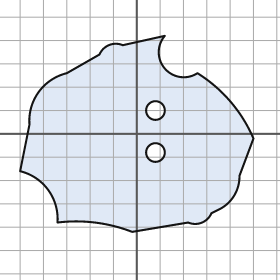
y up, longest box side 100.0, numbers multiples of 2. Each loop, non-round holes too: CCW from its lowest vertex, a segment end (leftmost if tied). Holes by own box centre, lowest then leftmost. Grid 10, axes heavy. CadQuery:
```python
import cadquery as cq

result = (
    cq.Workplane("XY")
    .moveTo(-2.0, -42.0)
    .lineTo(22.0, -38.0)
    .threePointArc((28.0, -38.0), (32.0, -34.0))
    .lineTo(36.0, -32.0)
    .threePointArc((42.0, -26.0), (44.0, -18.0))
    .lineTo(50.0, -2.0)
    .threePointArc((40.0, 14.0), (26.0, 26.0))
    .threePointArc((12.0, 28.0), (12.0, 42.0))
    .lineTo(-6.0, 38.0)
    .threePointArc((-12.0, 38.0), (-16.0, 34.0))
    .lineTo(-30.0, 26.0)
    .threePointArc((-42.0, 18.0), (-46.0, 4.0))
    .lineTo(-50.0, -16.0)
    .threePointArc((-38.0, -24.0), (-34.0, -38.0))
    .threePointArc((-18.0, -38.0), (-2.0, -42.0))
    .close()
    .moveTo(8.0, -8.0)
    .circle(4.0)
    .moveTo(8.0, 10.0)
    .circle(4.0)
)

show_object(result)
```